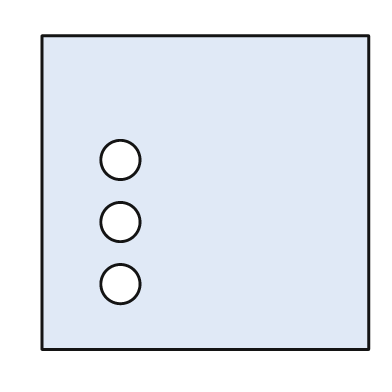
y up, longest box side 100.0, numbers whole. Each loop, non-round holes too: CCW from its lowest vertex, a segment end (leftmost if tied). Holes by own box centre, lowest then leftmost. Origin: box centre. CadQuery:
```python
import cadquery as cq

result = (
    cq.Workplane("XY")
    .moveTo(-50.0, -48.0)
    .lineTo(50.0, -48.0)
    .lineTo(50.0, 48.0)
    .lineTo(-50.0, 48.0)
    .close()
    .moveTo(-26.0, -28.0)
    .circle(6.0)
    .moveTo(-26.0, -9.0)
    .circle(6.0)
    .moveTo(-26.0, 10.0)
    .circle(6.0)
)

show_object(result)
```